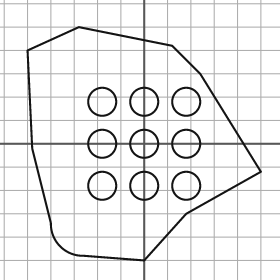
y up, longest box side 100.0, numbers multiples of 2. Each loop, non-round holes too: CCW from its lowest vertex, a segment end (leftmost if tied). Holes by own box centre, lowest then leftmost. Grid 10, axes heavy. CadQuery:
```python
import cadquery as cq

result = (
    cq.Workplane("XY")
    .moveTo(0.0, -50.0)
    .lineTo(18.0, -30.0)
    .lineTo(50.0, -12.0)
    .lineTo(24.0, 30.0)
    .lineTo(12.0, 42.0)
    .lineTo(-28.0, 50.0)
    .lineTo(-50.0, 40.0)
    .lineTo(-48.0, -2.0)
    .lineTo(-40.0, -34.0)
    .threePointArc((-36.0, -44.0), (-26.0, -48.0))
    .close()
    .moveTo(-18.0, -18.0)
    .circle(6.0)
    .moveTo(0.0, -18.0)
    .circle(6.0)
    .moveTo(18.0, -18.0)
    .circle(6.0)
    .moveTo(-18.0, 0.0)
    .circle(6.0)
    .moveTo(0.0, 0.0)
    .circle(6.0)
    .moveTo(18.0, 0.0)
    .circle(6.0)
    .moveTo(-18.0, 18.0)
    .circle(6.0)
    .moveTo(0.0, 18.0)
    .circle(6.0)
    .moveTo(18.0, 18.0)
    .circle(6.0)
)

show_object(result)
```